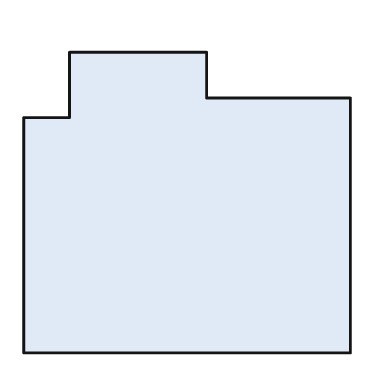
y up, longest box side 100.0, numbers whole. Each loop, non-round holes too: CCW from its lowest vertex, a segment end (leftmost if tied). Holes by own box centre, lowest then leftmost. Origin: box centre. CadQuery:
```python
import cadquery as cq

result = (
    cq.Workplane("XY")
    .moveTo(-50.0, -46.0)
    .lineTo(50.0, -46.0)
    .lineTo(50.0, 32.0)
    .lineTo(6.0, 32.0)
    .lineTo(6.0, 46.0)
    .lineTo(-36.0, 46.0)
    .lineTo(-36.0, 26.0)
    .lineTo(-50.0, 26.0)
    .close()
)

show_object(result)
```